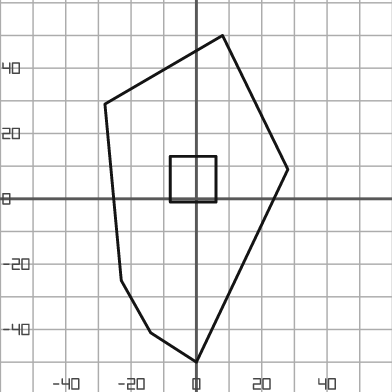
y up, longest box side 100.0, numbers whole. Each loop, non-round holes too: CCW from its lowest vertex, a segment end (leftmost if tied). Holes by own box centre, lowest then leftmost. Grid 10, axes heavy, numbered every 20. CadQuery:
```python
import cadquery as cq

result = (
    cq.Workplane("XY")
    .moveTo(0.0, -50.0)
    .lineTo(28.0, 9.0)
    .lineTo(8.0, 50.0)
    .lineTo(-28.0, 29.0)
    .lineTo(-23.0, -25.0)
    .lineTo(-14.0, -41.0)
    .close()
    .moveTo(-8.0, -1.0)
    .lineTo(6.0, -1.0)
    .lineTo(6.0, 13.0)
    .lineTo(-8.0, 13.0)
    .close()
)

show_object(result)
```